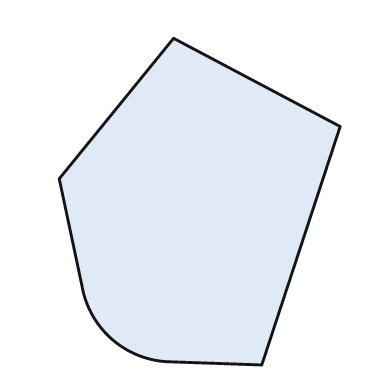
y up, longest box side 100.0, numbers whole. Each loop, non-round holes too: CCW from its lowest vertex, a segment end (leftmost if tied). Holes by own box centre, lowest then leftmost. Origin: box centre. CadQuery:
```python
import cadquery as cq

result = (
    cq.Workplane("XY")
    .moveTo(19.0, -50.0)
    .lineTo(43.0, 23.0)
    .lineTo(-8.0, 50.0)
    .lineTo(-43.0, 7.0)
    .lineTo(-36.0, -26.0)
    .threePointArc((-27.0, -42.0), (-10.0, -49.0))
    .close()
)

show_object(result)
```